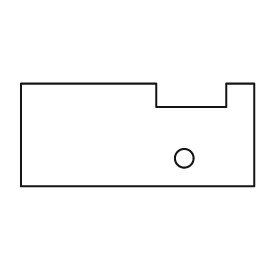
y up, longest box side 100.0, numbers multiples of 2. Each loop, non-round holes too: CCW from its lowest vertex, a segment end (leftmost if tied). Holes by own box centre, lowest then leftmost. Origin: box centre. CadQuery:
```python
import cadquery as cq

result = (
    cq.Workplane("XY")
    .moveTo(-50.0, -22.0)
    .lineTo(50.0, -22.0)
    .lineTo(50.0, 22.0)
    .lineTo(38.0, 22.0)
    .lineTo(38.0, 12.0)
    .lineTo(8.0, 12.0)
    .lineTo(8.0, 22.0)
    .lineTo(-50.0, 22.0)
    .close()
    .moveTo(20.0, -10.0)
    .circle(4.0)
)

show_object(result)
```